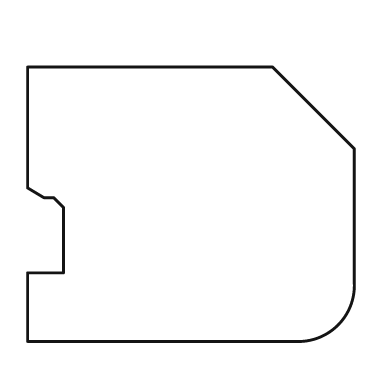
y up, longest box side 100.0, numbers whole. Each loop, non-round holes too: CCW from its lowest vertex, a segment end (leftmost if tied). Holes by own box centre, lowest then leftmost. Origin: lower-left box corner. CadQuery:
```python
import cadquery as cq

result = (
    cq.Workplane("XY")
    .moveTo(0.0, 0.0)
    .lineTo(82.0, 0.0)
    .threePointArc((95.0, 5.0), (100.0, 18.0))
    .lineTo(100.0, 59.0)
    .lineTo(75.0, 84.0)
    .lineTo(0.0, 84.0)
    .lineTo(0.0, 47.0)
    .lineTo(5.0, 44.0)
    .lineTo(8.0, 44.0)
    .lineTo(11.0, 41.0)
    .lineTo(11.0, 21.0)
    .lineTo(0.0, 21.0)
    .close()
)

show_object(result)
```